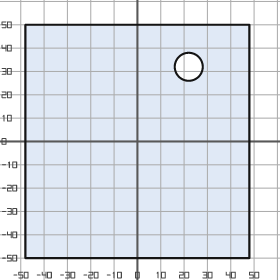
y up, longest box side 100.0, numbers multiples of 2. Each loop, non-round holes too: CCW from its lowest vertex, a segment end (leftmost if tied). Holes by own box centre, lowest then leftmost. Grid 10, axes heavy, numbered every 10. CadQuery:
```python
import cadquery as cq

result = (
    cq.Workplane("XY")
    .moveTo(-48.0, -50.0)
    .lineTo(48.0, -50.0)
    .lineTo(48.0, 50.0)
    .lineTo(-48.0, 50.0)
    .close()
    .moveTo(22.0, 32.0)
    .circle(6.0)
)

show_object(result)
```